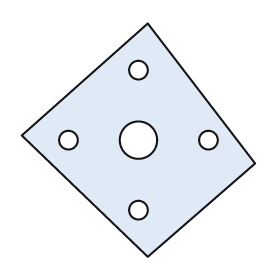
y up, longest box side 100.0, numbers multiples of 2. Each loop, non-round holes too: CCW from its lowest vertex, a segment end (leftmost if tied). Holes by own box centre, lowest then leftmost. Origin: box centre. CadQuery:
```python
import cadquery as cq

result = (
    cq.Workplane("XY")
    .moveTo(4.0, -50.0)
    .lineTo(50.0, -10.0)
    .lineTo(4.0, 50.0)
    .lineTo(-50.0, 2.0)
    .close()
    .moveTo(0.0, -30.0)
    .circle(4.0)
    .moveTo(-30.0, 0.0)
    .circle(4.0)
    .moveTo(0.0, 0.0)
    .circle(8.0)
    .moveTo(30.0, 0.0)
    .circle(4.0)
    .moveTo(0.0, 30.0)
    .circle(4.0)
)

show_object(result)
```